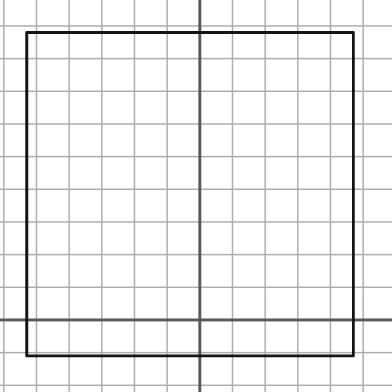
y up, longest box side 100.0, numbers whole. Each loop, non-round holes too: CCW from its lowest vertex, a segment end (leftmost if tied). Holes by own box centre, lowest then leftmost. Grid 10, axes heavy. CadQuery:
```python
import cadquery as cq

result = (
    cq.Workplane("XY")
    .moveTo(-53.0, -11.0)
    .lineTo(47.0, -11.0)
    .lineTo(47.0, 88.0)
    .lineTo(-53.0, 88.0)
    .close()
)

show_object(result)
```